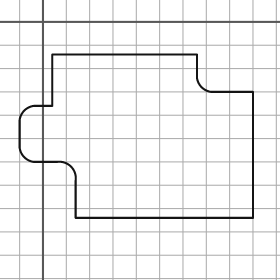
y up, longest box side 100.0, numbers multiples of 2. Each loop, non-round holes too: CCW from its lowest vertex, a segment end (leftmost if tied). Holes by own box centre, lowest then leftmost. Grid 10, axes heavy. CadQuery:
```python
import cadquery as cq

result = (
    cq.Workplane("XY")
    .moveTo(14.0, -84.0)
    .lineTo(90.0, -84.0)
    .lineTo(90.0, -30.0)
    .lineTo(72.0, -30.0)
    .threePointArc((68.0, -28.0), (66.0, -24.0))
    .lineTo(66.0, -14.0)
    .lineTo(4.0, -14.0)
    .lineTo(4.0, -36.0)
    .lineTo(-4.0, -36.0)
    .threePointArc((-8.0, -38.0), (-10.0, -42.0))
    .lineTo(-10.0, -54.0)
    .threePointArc((-8.0, -58.0), (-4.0, -60.0))
    .lineTo(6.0, -60.0)
    .threePointArc((12.0, -62.0), (14.0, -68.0))
    .close()
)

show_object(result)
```